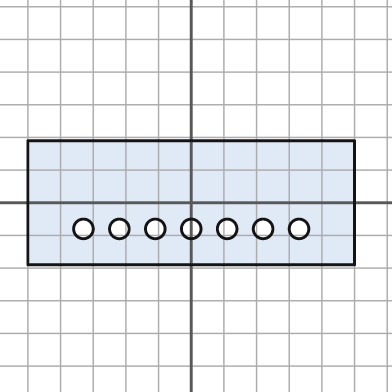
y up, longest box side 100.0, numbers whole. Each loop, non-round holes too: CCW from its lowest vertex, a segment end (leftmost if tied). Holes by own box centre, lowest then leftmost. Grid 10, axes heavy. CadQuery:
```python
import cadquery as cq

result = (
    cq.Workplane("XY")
    .moveTo(-50.0, -19.0)
    .lineTo(50.0, -19.0)
    .lineTo(50.0, 19.0)
    .lineTo(-50.0, 19.0)
    .close()
    .moveTo(-33.0, -8.0)
    .circle(3.0)
    .moveTo(-22.0, -8.0)
    .circle(3.0)
    .moveTo(-11.0, -8.0)
    .circle(3.0)
    .moveTo(0.0, -8.0)
    .circle(3.0)
    .moveTo(11.0, -8.0)
    .circle(3.0)
    .moveTo(22.0, -8.0)
    .circle(3.0)
    .moveTo(33.0, -8.0)
    .circle(3.0)
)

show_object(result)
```